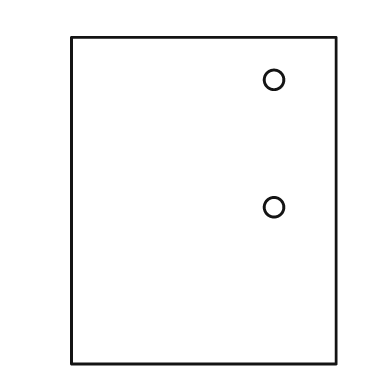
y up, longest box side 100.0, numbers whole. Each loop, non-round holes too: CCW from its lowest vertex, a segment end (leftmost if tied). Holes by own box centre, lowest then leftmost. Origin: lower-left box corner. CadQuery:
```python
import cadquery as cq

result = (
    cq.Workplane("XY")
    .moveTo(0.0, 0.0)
    .lineTo(81.0, 0.0)
    .lineTo(81.0, 100.0)
    .lineTo(0.0, 100.0)
    .close()
    .moveTo(62.0, 48.0)
    .circle(3.0)
    .moveTo(62.0, 87.0)
    .circle(3.0)
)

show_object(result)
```